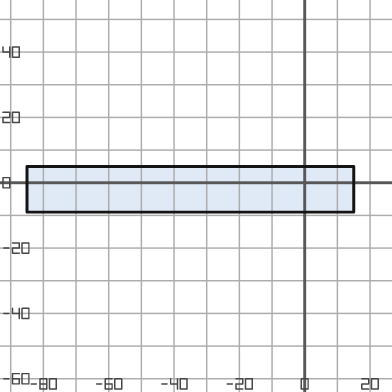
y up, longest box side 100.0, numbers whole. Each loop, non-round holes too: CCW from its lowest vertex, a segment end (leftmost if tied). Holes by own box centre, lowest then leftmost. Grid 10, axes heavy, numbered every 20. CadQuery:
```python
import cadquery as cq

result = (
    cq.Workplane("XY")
    .moveTo(-85.0, -9.0)
    .lineTo(15.0, -9.0)
    .lineTo(15.0, 5.0)
    .lineTo(-85.0, 5.0)
    .close()
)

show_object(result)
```